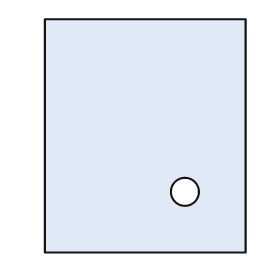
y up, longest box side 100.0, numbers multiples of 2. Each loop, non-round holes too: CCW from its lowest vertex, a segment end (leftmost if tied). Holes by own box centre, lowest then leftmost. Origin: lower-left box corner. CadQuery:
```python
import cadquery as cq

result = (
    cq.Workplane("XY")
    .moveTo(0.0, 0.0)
    .lineTo(86.0, 0.0)
    .lineTo(86.0, 100.0)
    .lineTo(0.0, 100.0)
    .close()
    .moveTo(60.0, 26.0)
    .circle(6.0)
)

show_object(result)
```